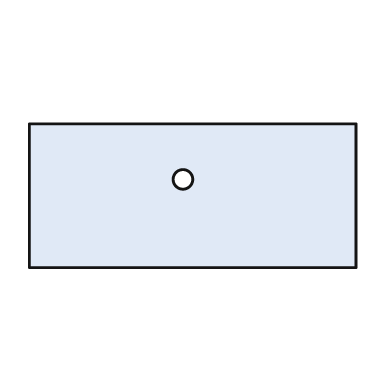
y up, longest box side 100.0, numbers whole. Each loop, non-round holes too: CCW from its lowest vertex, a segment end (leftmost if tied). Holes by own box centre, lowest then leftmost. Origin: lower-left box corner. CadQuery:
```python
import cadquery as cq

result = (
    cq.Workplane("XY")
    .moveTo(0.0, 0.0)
    .lineTo(100.0, 0.0)
    .lineTo(100.0, 44.0)
    .lineTo(0.0, 44.0)
    .close()
    .moveTo(47.0, 27.0)
    .circle(3.0)
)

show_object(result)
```